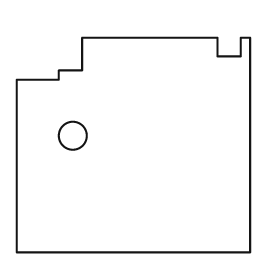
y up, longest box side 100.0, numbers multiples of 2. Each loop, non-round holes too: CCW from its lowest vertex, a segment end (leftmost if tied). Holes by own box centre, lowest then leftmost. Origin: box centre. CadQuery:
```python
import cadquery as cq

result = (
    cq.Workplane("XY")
    .moveTo(-50.0, -46.0)
    .lineTo(50.0, -46.0)
    .lineTo(50.0, 46.0)
    .lineTo(46.0, 46.0)
    .lineTo(46.0, 38.0)
    .lineTo(36.0, 38.0)
    .lineTo(36.0, 46.0)
    .lineTo(-22.0, 46.0)
    .lineTo(-22.0, 32.0)
    .lineTo(-32.0, 32.0)
    .lineTo(-32.0, 28.0)
    .lineTo(-50.0, 28.0)
    .close()
    .moveTo(-26.0, 4.0)
    .circle(6.0)
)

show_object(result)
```